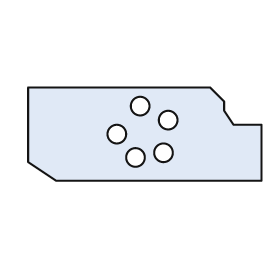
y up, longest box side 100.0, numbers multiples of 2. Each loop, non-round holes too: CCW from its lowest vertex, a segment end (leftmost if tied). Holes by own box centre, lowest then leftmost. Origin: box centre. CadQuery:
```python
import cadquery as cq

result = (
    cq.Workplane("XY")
    .moveTo(-38.0, -20.0)
    .lineTo(50.0, -20.0)
    .lineTo(50.0, 4.0)
    .lineTo(38.0, 4.0)
    .lineTo(34.0, 10.0)
    .lineTo(34.0, 14.0)
    .lineTo(28.0, 20.0)
    .lineTo(-50.0, 20.0)
    .lineTo(-50.0, -12.0)
    .close()
    .moveTo(-4.0, -10.0)
    .circle(4.0)
    .moveTo(8.0, -8.0)
    .circle(4.0)
    .moveTo(-12.0, 0.0)
    .circle(4.0)
    .moveTo(10.0, 6.0)
    .circle(4.0)
    .moveTo(-2.0, 12.0)
    .circle(4.0)
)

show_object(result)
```